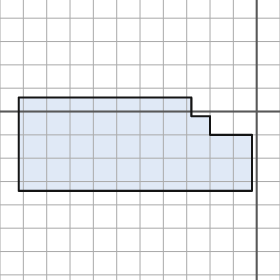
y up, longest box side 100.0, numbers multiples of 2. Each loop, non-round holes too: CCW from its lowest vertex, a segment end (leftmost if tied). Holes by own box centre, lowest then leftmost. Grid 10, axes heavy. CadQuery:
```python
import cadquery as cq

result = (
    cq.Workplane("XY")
    .moveTo(-102.0, -34.0)
    .lineTo(-2.0, -34.0)
    .lineTo(-2.0, -10.0)
    .lineTo(-20.0, -10.0)
    .lineTo(-20.0, -2.0)
    .lineTo(-28.0, -2.0)
    .lineTo(-28.0, 6.0)
    .lineTo(-102.0, 6.0)
    .close()
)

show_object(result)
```